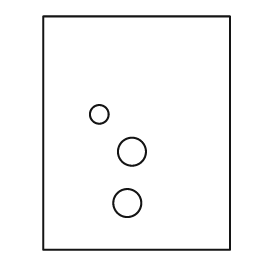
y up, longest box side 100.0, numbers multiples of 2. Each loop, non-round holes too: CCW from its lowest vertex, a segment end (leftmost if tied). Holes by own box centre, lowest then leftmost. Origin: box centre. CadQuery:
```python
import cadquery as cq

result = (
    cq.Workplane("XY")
    .moveTo(-40.0, -50.0)
    .lineTo(40.0, -50.0)
    .lineTo(40.0, 50.0)
    .lineTo(-40.0, 50.0)
    .close()
    .moveTo(-4.0, -30.0)
    .circle(6.0)
    .moveTo(-2.0, -8.0)
    .circle(6.0)
    .moveTo(-16.0, 8.0)
    .circle(4.0)
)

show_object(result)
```